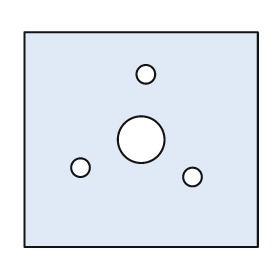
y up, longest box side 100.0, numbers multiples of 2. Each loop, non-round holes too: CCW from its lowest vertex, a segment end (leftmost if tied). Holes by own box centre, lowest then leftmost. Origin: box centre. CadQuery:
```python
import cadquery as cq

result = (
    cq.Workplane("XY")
    .moveTo(-50.0, -46.0)
    .lineTo(50.0, -46.0)
    .lineTo(50.0, 46.0)
    .lineTo(-50.0, 46.0)
    .close()
    .moveTo(22.0, -16.0)
    .circle(4.0)
    .moveTo(-26.0, -12.0)
    .circle(4.0)
    .moveTo(0.0, 0.0)
    .circle(10.0)
    .moveTo(2.0, 28.0)
    .circle(4.0)
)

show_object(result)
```